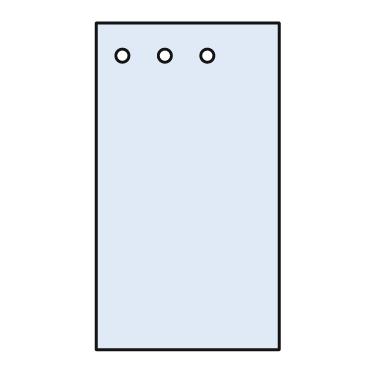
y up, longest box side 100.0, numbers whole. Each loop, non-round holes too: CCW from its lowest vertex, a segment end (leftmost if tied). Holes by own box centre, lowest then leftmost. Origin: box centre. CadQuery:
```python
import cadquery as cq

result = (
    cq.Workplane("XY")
    .moveTo(-28.0, -50.0)
    .lineTo(28.0, -50.0)
    .lineTo(28.0, 50.0)
    .lineTo(-28.0, 50.0)
    .close()
    .moveTo(-20.0, 40.0)
    .circle(2.0)
    .moveTo(-7.0, 40.0)
    .circle(2.0)
    .moveTo(6.0, 40.0)
    .circle(2.0)
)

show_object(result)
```